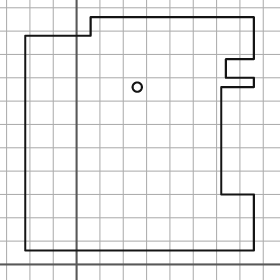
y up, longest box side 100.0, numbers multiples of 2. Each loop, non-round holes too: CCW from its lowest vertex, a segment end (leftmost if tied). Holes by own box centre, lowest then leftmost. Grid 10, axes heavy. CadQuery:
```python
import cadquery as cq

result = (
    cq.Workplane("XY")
    .moveTo(-22.0, 6.0)
    .lineTo(76.0, 6.0)
    .lineTo(76.0, 30.0)
    .lineTo(62.0, 30.0)
    .lineTo(62.0, 76.0)
    .lineTo(76.0, 76.0)
    .lineTo(76.0, 80.0)
    .lineTo(64.0, 80.0)
    .lineTo(64.0, 88.0)
    .lineTo(76.0, 88.0)
    .lineTo(76.0, 106.0)
    .lineTo(6.0, 106.0)
    .lineTo(6.0, 98.0)
    .lineTo(-22.0, 98.0)
    .close()
    .moveTo(26.0, 76.0)
    .circle(2.0)
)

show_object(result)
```